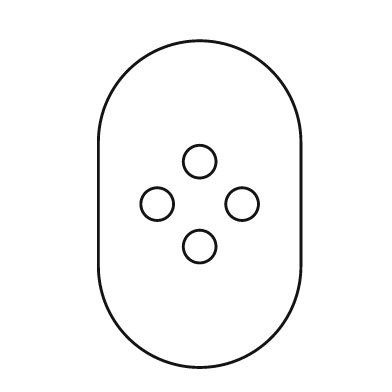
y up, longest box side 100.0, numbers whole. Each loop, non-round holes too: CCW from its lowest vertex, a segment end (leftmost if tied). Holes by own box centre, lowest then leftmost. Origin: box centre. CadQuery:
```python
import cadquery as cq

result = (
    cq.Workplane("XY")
    .moveTo(-31.0, -19.0)
    .threePointArc((0.0, -50.0), (31.0, -19.0))
    .lineTo(31.0, 19.0)
    .threePointArc((0.0, 50.0), (-31.0, 19.0))
    .close()
    .moveTo(0.0, -13.0)
    .circle(5.0)
    .moveTo(-13.0, 0.0)
    .circle(5.0)
    .moveTo(13.0, 0.0)
    .circle(5.0)
    .moveTo(0.0, 13.0)
    .circle(5.0)
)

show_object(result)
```